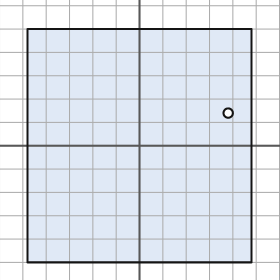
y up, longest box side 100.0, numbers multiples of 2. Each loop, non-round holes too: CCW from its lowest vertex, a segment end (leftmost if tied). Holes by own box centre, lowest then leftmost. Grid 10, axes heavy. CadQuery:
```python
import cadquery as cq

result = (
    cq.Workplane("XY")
    .moveTo(-48.0, -50.0)
    .lineTo(48.0, -50.0)
    .lineTo(48.0, 50.0)
    .lineTo(-48.0, 50.0)
    .close()
    .moveTo(38.0, 14.0)
    .circle(2.0)
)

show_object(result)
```